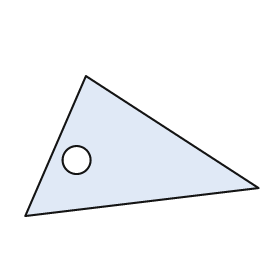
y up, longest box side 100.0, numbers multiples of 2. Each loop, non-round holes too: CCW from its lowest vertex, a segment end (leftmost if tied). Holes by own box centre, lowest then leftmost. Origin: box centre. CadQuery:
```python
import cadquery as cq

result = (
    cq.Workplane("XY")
    .moveTo(-50.0, -30.0)
    .lineTo(50.0, -18.0)
    .lineTo(-24.0, 30.0)
    .close()
    .moveTo(-28.0, -6.0)
    .circle(6.0)
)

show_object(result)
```